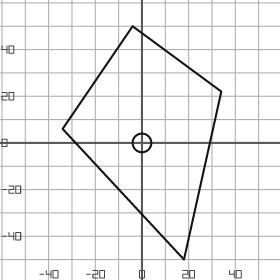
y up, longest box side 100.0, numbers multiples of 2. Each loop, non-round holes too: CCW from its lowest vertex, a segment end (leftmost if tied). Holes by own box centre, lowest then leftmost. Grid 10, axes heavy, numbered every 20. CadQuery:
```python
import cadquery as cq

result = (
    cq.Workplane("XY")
    .moveTo(18.0, -50.0)
    .lineTo(34.0, 22.0)
    .lineTo(-4.0, 50.0)
    .lineTo(-34.0, 6.0)
    .close()
    .moveTo(0.0, 0.0)
    .circle(4.0)
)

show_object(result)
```